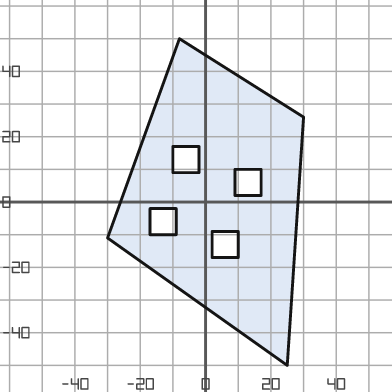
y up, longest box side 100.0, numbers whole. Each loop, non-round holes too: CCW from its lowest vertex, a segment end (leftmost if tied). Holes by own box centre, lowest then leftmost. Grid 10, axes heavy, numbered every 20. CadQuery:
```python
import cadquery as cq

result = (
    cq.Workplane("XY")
    .moveTo(25.0, -50.0)
    .lineTo(30.0, 26.0)
    .lineTo(-8.0, 50.0)
    .lineTo(-30.0, -11.0)
    .close()
    .moveTo(2.0, -17.0)
    .lineTo(10.0, -17.0)
    .lineTo(10.0, -9.0)
    .lineTo(2.0, -9.0)
    .close()
    .moveTo(-17.0, -10.0)
    .lineTo(-9.0, -10.0)
    .lineTo(-9.0, -2.0)
    .lineTo(-17.0, -2.0)
    .close()
    .moveTo(9.0, 2.0)
    .lineTo(17.0, 2.0)
    .lineTo(17.0, 10.0)
    .lineTo(9.0, 10.0)
    .close()
    .moveTo(-10.0, 9.0)
    .lineTo(-2.0, 9.0)
    .lineTo(-2.0, 17.0)
    .lineTo(-10.0, 17.0)
    .close()
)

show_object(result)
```